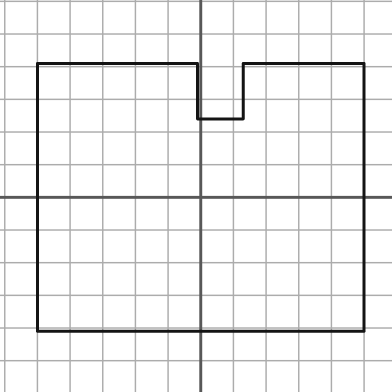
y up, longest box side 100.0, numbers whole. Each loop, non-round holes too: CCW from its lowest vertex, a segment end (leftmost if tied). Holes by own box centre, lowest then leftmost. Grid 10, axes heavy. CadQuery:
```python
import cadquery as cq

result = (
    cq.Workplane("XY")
    .moveTo(-50.0, -41.0)
    .lineTo(50.0, -41.0)
    .lineTo(50.0, 41.0)
    .lineTo(13.0, 41.0)
    .lineTo(13.0, 24.0)
    .lineTo(-1.0, 24.0)
    .lineTo(-1.0, 41.0)
    .lineTo(-50.0, 41.0)
    .close()
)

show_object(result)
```